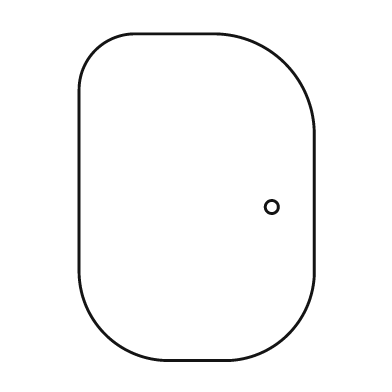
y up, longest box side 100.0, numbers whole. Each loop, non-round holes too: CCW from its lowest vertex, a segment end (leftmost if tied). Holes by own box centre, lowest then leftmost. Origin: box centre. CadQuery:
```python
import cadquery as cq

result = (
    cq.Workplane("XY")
    .moveTo(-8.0, -50.0)
    .lineTo(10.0, -50.0)
    .threePointArc((28.0, -42.0), (36.0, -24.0))
    .lineTo(36.0, 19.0)
    .threePointArc((27.0, 41.0), (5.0, 50.0))
    .lineTo(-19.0, 50.0)
    .threePointArc((-31.0, 45.0), (-36.0, 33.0))
    .lineTo(-36.0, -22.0)
    .threePointArc((-28.0, -42.0), (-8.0, -50.0))
    .close()
    .moveTo(23.0, -3.0)
    .circle(2.0)
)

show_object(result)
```